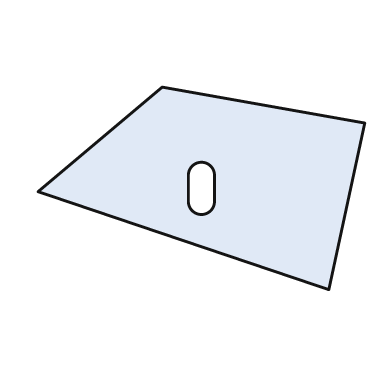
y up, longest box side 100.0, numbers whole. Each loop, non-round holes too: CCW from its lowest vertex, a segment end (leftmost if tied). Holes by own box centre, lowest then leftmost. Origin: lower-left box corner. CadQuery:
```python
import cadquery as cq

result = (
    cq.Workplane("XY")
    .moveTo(89.0, 0.0)
    .lineTo(100.0, 51.0)
    .lineTo(38.0, 62.0)
    .lineTo(0.0, 30.0)
    .close()
    .moveTo(46.0, 27.0)
    .threePointArc((50.0, 23.0), (54.0, 27.0))
    .lineTo(54.0, 35.0)
    .threePointArc((50.0, 39.0), (46.0, 35.0))
    .close()
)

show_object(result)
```